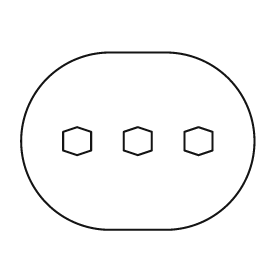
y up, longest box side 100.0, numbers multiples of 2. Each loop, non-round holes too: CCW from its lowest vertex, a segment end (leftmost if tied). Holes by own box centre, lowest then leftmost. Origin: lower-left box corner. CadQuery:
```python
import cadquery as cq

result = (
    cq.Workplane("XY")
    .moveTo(38.0, 0.0)
    .lineTo(62.0, 0.0)
    .threePointArc((100.0, 38.0), (62.0, 76.0))
    .lineTo(38.0, 76.0)
    .threePointArc((0.0, 38.0), (38.0, 0.0))
    .close()
    .moveTo(24.0, 32.0)
    .lineTo(30.0, 34.0)
    .lineTo(30.0, 42.0)
    .lineTo(24.0, 44.0)
    .lineTo(18.0, 42.0)
    .lineTo(18.0, 34.0)
    .close()
    .moveTo(50.0, 32.0)
    .lineTo(56.0, 34.0)
    .lineTo(56.0, 42.0)
    .lineTo(50.0, 44.0)
    .lineTo(44.0, 42.0)
    .lineTo(44.0, 34.0)
    .close()
    .moveTo(76.0, 32.0)
    .lineTo(82.0, 34.0)
    .lineTo(82.0, 42.0)
    .lineTo(76.0, 44.0)
    .lineTo(70.0, 42.0)
    .lineTo(70.0, 34.0)
    .close()
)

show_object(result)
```